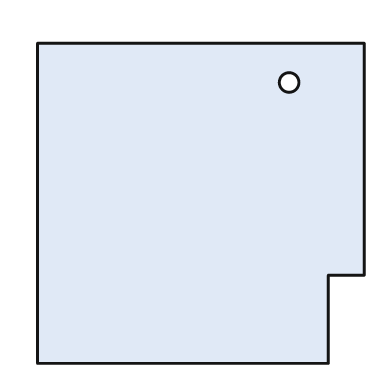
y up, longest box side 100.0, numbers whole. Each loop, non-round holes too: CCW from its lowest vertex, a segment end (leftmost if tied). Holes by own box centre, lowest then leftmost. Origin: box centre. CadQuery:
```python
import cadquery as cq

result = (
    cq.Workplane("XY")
    .moveTo(-50.0, -49.0)
    .lineTo(39.0, -49.0)
    .lineTo(39.0, -22.0)
    .lineTo(50.0, -22.0)
    .lineTo(50.0, 49.0)
    .lineTo(-50.0, 49.0)
    .close()
    .moveTo(27.0, 37.0)
    .circle(3.0)
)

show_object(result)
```